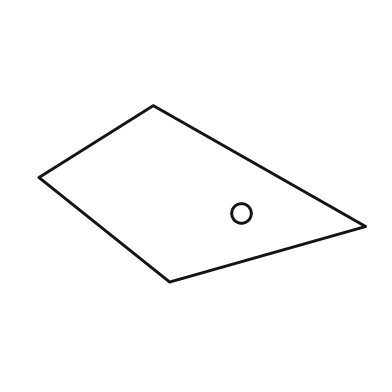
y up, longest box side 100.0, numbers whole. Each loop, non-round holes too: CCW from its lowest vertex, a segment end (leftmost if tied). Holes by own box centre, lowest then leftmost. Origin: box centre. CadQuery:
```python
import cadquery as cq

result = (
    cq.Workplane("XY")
    .moveTo(-10.0, -27.0)
    .lineTo(50.0, -10.0)
    .lineTo(-15.0, 27.0)
    .lineTo(-50.0, 5.0)
    .close()
    .moveTo(12.0, -6.0)
    .circle(3.0)
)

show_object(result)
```